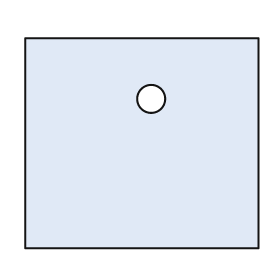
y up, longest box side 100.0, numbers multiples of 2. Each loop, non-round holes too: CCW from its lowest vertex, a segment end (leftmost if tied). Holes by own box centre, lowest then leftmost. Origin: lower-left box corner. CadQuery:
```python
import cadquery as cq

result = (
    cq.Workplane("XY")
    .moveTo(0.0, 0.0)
    .lineTo(100.0, 0.0)
    .lineTo(100.0, 90.0)
    .lineTo(0.0, 90.0)
    .close()
    .moveTo(54.0, 64.0)
    .circle(6.0)
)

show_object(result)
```